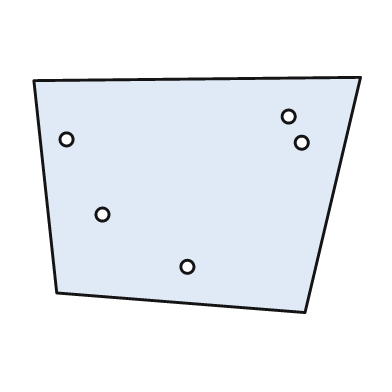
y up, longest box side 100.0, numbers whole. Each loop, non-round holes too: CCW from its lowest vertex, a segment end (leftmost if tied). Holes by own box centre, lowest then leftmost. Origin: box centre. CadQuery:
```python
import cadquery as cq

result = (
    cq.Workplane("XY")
    .moveTo(33.0, -36.0)
    .lineTo(50.0, 36.0)
    .lineTo(-50.0, 35.0)
    .lineTo(-43.0, -30.0)
    .close()
    .moveTo(-3.0, -22.0)
    .circle(2.0)
    .moveTo(-29.0, -6.0)
    .circle(2.0)
    .moveTo(32.0, 16.0)
    .circle(2.0)
    .moveTo(-40.0, 17.0)
    .circle(2.0)
    .moveTo(28.0, 24.0)
    .circle(2.0)
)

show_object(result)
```